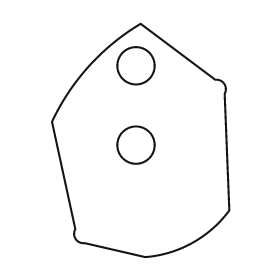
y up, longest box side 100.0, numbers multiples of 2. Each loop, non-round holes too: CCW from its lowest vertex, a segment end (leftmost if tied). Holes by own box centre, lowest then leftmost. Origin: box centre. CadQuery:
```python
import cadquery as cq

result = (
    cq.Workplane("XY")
    .moveTo(2.0, -50.0)
    .threePointArc((22.0, -44.0), (38.0, -30.0))
    .lineTo(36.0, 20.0)
    .threePointArc((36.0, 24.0), (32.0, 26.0))
    .lineTo(0.0, 50.0)
    .threePointArc((-22.0, 32.0), (-38.0, 8.0))
    .lineTo(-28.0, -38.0)
    .threePointArc((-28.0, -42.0), (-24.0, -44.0))
    .close()
    .moveTo(-2.0, -2.0)
    .circle(8.0)
    .moveTo(-2.0, 32.0)
    .circle(8.0)
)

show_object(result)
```